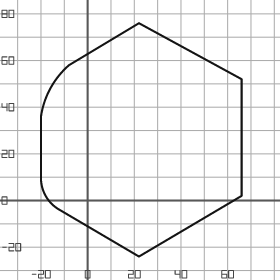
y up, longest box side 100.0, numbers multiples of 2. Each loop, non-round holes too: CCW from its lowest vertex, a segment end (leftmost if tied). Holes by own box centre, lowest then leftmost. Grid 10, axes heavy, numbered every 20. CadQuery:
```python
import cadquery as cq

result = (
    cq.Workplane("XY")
    .moveTo(22.0, -24.0)
    .lineTo(66.0, 2.0)
    .lineTo(66.0, 52.0)
    .lineTo(22.0, 76.0)
    .lineTo(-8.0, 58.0)
    .threePointArc((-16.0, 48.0), (-20.0, 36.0))
    .lineTo(-20.0, 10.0)
    .threePointArc((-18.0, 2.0), (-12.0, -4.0))
    .close()
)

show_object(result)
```